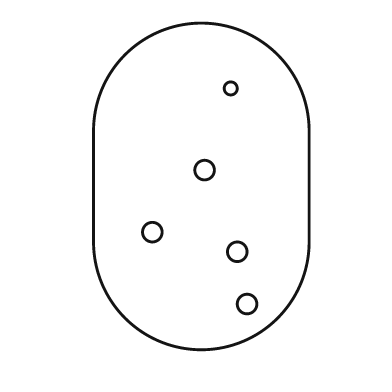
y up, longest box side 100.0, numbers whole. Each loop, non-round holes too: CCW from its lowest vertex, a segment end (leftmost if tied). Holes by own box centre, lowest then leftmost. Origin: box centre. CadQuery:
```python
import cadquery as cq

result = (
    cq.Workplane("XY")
    .moveTo(-33.0, -17.0)
    .threePointArc((0.0, -50.0), (33.0, -17.0))
    .lineTo(33.0, 17.0)
    .threePointArc((0.0, 50.0), (-33.0, 17.0))
    .close()
    .moveTo(14.0, -36.0)
    .circle(3.0)
    .moveTo(11.0, -20.0)
    .circle(3.0)
    .moveTo(-15.0, -14.0)
    .circle(3.0)
    .moveTo(1.0, 5.0)
    .circle(3.0)
    .moveTo(9.0, 30.0)
    .circle(2.0)
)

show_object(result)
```